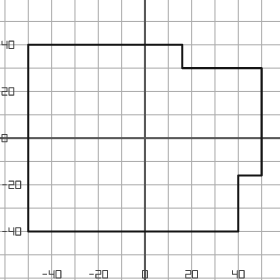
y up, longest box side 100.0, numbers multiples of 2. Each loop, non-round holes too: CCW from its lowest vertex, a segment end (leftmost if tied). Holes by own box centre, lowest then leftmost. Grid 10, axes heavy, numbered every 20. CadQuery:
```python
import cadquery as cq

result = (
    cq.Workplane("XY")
    .moveTo(-50.0, -40.0)
    .lineTo(40.0, -40.0)
    .lineTo(40.0, -16.0)
    .lineTo(50.0, -16.0)
    .lineTo(50.0, 30.0)
    .lineTo(16.0, 30.0)
    .lineTo(16.0, 40.0)
    .lineTo(-50.0, 40.0)
    .close()
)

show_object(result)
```